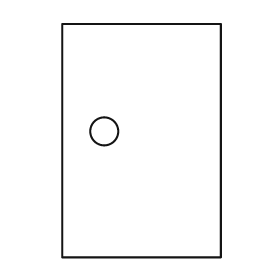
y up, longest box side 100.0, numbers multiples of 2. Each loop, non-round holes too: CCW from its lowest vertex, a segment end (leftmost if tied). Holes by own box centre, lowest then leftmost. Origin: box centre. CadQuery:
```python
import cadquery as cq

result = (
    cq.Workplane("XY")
    .moveTo(-34.0, -50.0)
    .lineTo(34.0, -50.0)
    .lineTo(34.0, 50.0)
    .lineTo(-34.0, 50.0)
    .close()
    .moveTo(-16.0, 4.0)
    .circle(6.0)
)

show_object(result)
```